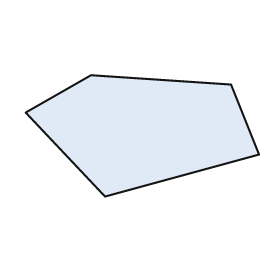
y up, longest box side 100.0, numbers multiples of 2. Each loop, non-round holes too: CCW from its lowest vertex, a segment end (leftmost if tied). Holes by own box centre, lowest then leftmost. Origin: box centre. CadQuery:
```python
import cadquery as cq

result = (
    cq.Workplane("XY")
    .moveTo(-16.0, -26.0)
    .lineTo(50.0, -8.0)
    .lineTo(38.0, 22.0)
    .lineTo(-22.0, 26.0)
    .lineTo(-50.0, 10.0)
    .close()
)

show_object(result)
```